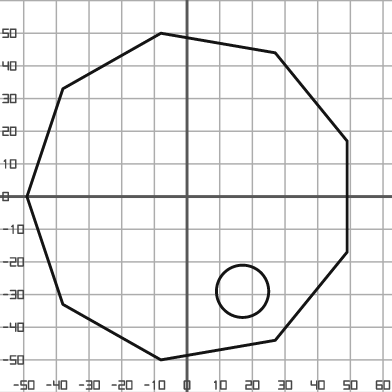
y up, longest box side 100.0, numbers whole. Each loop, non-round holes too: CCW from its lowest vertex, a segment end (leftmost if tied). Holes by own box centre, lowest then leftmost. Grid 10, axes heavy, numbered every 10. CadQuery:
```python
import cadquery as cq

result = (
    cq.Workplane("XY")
    .moveTo(-8.0, -50.0)
    .lineTo(27.0, -44.0)
    .lineTo(49.0, -17.0)
    .lineTo(49.0, 17.0)
    .lineTo(27.0, 44.0)
    .lineTo(-8.0, 50.0)
    .lineTo(-38.0, 33.0)
    .lineTo(-49.0, 0.0)
    .lineTo(-38.0, -33.0)
    .close()
    .moveTo(17.0, -29.0)
    .circle(8.0)
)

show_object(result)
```